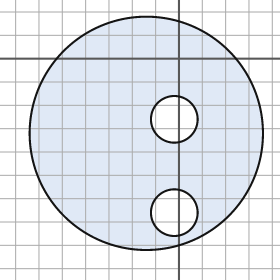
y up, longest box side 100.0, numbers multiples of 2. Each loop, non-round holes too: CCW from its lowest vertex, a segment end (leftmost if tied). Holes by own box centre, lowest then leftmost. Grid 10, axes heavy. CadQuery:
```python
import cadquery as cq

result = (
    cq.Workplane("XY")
    .moveTo(-14.0, -32.0)
    .circle(50.0)
    .moveTo(-2.0, -66.0)
    .circle(10.0)
    .moveTo(-2.0, -26.0)
    .circle(10.0)
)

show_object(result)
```